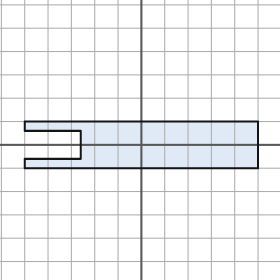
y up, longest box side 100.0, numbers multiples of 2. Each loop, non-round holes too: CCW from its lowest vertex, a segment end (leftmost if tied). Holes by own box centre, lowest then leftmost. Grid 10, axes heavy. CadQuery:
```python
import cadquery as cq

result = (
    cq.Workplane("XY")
    .moveTo(-50.0, -10.0)
    .lineTo(50.0, -10.0)
    .lineTo(50.0, 10.0)
    .lineTo(-50.0, 10.0)
    .lineTo(-50.0, 6.0)
    .lineTo(-26.0, 6.0)
    .lineTo(-26.0, -6.0)
    .lineTo(-50.0, -6.0)
    .close()
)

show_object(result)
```